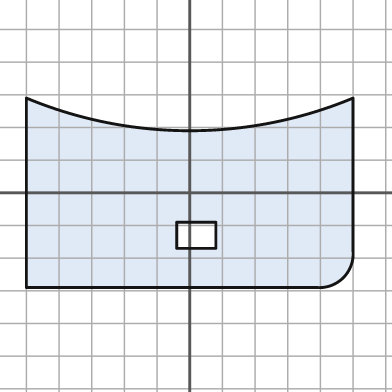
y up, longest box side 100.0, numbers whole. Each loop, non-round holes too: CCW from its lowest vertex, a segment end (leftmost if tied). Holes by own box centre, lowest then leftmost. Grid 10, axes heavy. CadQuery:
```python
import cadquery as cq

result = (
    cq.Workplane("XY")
    .moveTo(-50.0, -29.0)
    .lineTo(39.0, -29.0)
    .threePointArc((47.0, -26.0), (50.0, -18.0))
    .lineTo(50.0, 29.0)
    .threePointArc((0.0, 19.0), (-50.0, 29.0))
    .close()
    .moveTo(-4.0, -17.0)
    .lineTo(8.0, -17.0)
    .lineTo(8.0, -9.0)
    .lineTo(-4.0, -9.0)
    .close()
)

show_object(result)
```